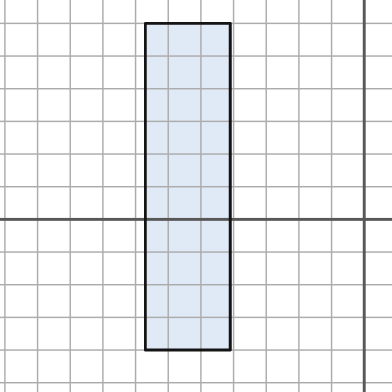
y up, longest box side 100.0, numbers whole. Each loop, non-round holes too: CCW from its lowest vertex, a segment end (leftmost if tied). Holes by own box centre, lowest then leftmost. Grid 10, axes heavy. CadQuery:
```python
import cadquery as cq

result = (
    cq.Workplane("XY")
    .moveTo(-67.0, -40.0)
    .lineTo(-41.0, -40.0)
    .lineTo(-41.0, 60.0)
    .lineTo(-67.0, 60.0)
    .close()
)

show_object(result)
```